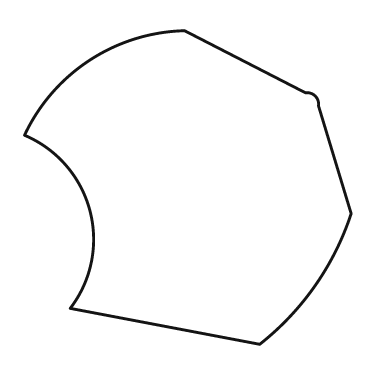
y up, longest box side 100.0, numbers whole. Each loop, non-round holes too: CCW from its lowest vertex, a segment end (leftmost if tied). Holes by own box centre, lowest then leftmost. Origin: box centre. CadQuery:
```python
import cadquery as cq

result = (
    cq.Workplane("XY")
    .moveTo(22.0, -48.0)
    .threePointArc((39.0, -30.0), (50.0, -8.0))
    .lineTo(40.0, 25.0)
    .threePointArc((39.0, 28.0), (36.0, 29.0))
    .lineTo(-1.0, 48.0)
    .threePointArc((-30.0, 39.0), (-50.0, 16.0))
    .threePointArc((-30.0, -7.0), (-36.0, -37.0))
    .close()
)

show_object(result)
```